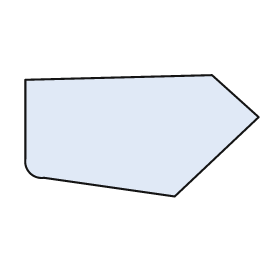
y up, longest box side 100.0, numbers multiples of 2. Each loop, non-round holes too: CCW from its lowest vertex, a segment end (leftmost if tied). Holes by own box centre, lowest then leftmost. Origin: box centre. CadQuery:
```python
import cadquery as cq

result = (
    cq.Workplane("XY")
    .moveTo(14.0, -26.0)
    .lineTo(50.0, 8.0)
    .lineTo(30.0, 26.0)
    .lineTo(-50.0, 24.0)
    .lineTo(-50.0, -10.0)
    .threePointArc((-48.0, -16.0), (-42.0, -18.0))
    .close()
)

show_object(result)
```